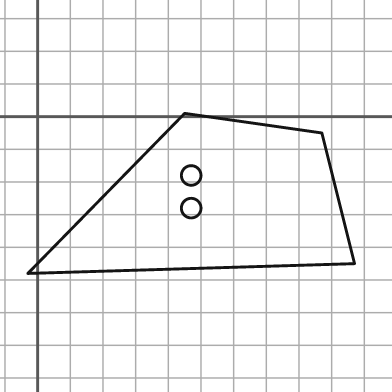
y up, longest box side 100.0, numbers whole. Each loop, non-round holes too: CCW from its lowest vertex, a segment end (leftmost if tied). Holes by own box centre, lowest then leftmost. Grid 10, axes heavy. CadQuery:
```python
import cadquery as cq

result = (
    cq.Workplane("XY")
    .moveTo(-3.0, -48.0)
    .lineTo(97.0, -45.0)
    .lineTo(87.0, -5.0)
    .lineTo(45.0, 1.0)
    .close()
    .moveTo(47.0, -28.0)
    .circle(3.0)
    .moveTo(47.0, -18.0)
    .circle(3.0)
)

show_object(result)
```